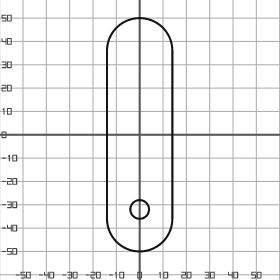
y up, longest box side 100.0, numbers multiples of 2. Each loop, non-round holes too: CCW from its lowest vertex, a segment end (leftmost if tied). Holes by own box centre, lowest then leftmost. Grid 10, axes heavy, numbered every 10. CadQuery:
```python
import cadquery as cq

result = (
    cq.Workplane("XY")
    .moveTo(-14.0, -36.0)
    .threePointArc((0.0, -50.0), (14.0, -36.0))
    .lineTo(14.0, 36.0)
    .threePointArc((0.0, 50.0), (-14.0, 36.0))
    .close()
    .moveTo(0.0, -32.0)
    .circle(4.0)
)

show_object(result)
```